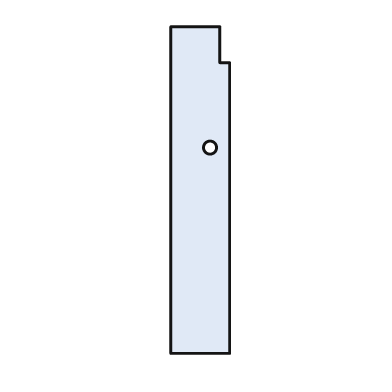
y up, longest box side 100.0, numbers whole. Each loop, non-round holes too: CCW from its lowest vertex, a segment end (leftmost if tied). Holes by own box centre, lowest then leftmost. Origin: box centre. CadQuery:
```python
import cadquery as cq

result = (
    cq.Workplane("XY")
    .moveTo(-9.0, -50.0)
    .lineTo(9.0, -50.0)
    .lineTo(9.0, 39.0)
    .lineTo(6.0, 39.0)
    .lineTo(6.0, 50.0)
    .lineTo(-9.0, 50.0)
    .close()
    .moveTo(3.0, 13.0)
    .circle(2.0)
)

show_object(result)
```